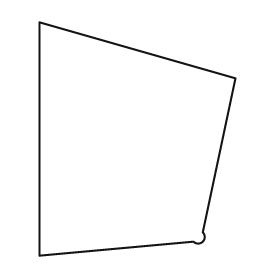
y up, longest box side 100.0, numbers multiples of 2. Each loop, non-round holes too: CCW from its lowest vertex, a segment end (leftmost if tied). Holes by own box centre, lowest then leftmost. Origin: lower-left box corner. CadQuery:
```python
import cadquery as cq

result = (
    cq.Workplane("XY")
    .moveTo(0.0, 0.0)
    .lineTo(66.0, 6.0)
    .threePointArc((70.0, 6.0), (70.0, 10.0))
    .lineTo(84.0, 76.0)
    .lineTo(0.0, 100.0)
    .close()
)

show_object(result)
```